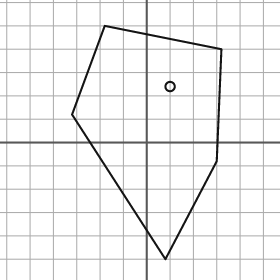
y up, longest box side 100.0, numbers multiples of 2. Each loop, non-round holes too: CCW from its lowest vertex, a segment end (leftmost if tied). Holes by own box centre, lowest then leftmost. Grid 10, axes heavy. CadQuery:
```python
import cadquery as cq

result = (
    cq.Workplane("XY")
    .moveTo(8.0, -50.0)
    .lineTo(30.0, -8.0)
    .lineTo(32.0, 40.0)
    .lineTo(-18.0, 50.0)
    .lineTo(-32.0, 12.0)
    .close()
    .moveTo(10.0, 24.0)
    .circle(2.0)
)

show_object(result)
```